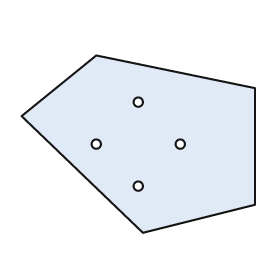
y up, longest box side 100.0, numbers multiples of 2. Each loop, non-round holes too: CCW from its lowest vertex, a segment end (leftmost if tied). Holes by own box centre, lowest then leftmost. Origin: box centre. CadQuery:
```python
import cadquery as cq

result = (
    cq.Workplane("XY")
    .moveTo(2.0, -38.0)
    .lineTo(50.0, -26.0)
    .lineTo(50.0, 24.0)
    .lineTo(-18.0, 38.0)
    .lineTo(-50.0, 12.0)
    .close()
    .moveTo(0.0, -18.0)
    .circle(2.0)
    .moveTo(-18.0, 0.0)
    .circle(2.0)
    .moveTo(18.0, 0.0)
    .circle(2.0)
    .moveTo(0.0, 18.0)
    .circle(2.0)
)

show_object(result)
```